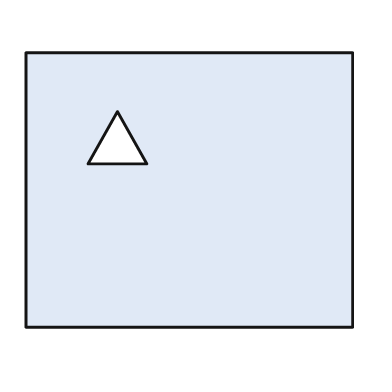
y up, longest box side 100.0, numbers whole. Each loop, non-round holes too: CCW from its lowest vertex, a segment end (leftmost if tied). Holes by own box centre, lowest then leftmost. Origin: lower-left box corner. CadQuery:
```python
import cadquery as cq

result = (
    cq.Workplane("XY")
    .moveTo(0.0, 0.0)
    .lineTo(100.0, 0.0)
    .lineTo(100.0, 84.0)
    .lineTo(0.0, 84.0)
    .close()
    .moveTo(19.0, 50.0)
    .lineTo(37.0, 50.0)
    .lineTo(28.0, 66.0)
    .close()
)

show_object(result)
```